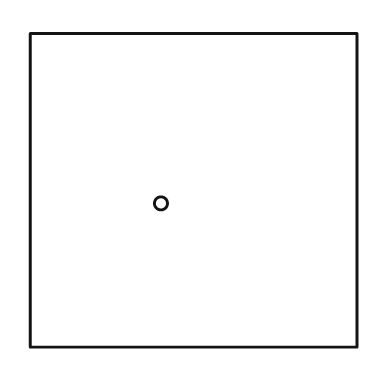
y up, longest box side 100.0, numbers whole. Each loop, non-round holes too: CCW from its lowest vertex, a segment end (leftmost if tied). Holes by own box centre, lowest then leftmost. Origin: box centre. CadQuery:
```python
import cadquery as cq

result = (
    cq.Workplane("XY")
    .moveTo(-50.0, -48.0)
    .lineTo(50.0, -48.0)
    .lineTo(50.0, 48.0)
    .lineTo(-50.0, 48.0)
    .close()
    .moveTo(-10.0, -4.0)
    .circle(2.0)
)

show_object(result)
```